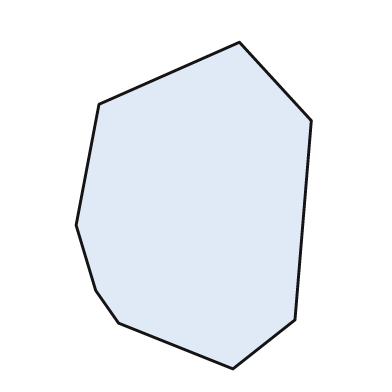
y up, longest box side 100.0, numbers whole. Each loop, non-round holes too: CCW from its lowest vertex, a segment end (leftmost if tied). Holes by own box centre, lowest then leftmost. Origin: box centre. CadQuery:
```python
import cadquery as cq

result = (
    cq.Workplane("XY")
    .moveTo(12.0, -50.0)
    .lineTo(31.0, -35.0)
    .lineTo(36.0, 26.0)
    .lineTo(14.0, 50.0)
    .lineTo(-29.0, 31.0)
    .lineTo(-36.0, -6.0)
    .lineTo(-30.0, -26.0)
    .lineTo(-23.0, -36.0)
    .close()
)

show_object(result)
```